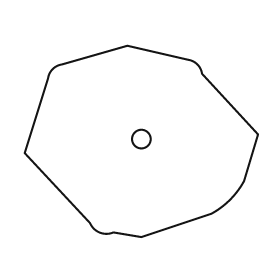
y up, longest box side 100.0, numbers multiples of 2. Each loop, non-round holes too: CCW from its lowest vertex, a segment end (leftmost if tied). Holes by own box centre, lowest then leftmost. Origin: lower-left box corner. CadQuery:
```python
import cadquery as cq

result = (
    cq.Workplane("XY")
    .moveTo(50.0, 0.0)
    .lineTo(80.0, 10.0)
    .threePointArc((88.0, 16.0), (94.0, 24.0))
    .lineTo(100.0, 44.0)
    .lineTo(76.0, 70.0)
    .threePointArc((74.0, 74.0), (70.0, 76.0))
    .lineTo(44.0, 82.0)
    .lineTo(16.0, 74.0)
    .threePointArc((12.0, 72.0), (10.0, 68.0))
    .lineTo(0.0, 36.0)
    .lineTo(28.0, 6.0)
    .threePointArc((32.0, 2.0), (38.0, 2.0))
    .close()
    .moveTo(50.0, 42.0)
    .circle(4.0)
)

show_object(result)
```